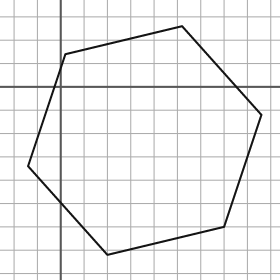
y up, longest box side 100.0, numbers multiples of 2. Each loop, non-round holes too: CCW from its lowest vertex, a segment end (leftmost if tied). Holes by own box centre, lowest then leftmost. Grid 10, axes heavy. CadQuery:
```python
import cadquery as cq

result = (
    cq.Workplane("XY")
    .moveTo(20.0, -72.0)
    .lineTo(70.0, -60.0)
    .lineTo(86.0, -12.0)
    .lineTo(52.0, 26.0)
    .lineTo(2.0, 14.0)
    .lineTo(-14.0, -34.0)
    .close()
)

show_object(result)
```